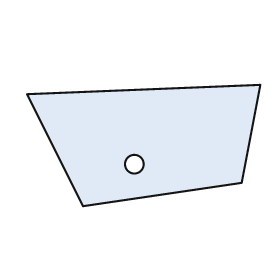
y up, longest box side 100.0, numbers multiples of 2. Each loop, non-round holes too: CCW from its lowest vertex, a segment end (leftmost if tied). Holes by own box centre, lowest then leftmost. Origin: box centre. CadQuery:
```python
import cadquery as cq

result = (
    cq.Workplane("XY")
    .moveTo(-26.0, -26.0)
    .lineTo(42.0, -16.0)
    .lineTo(50.0, 26.0)
    .lineTo(-50.0, 22.0)
    .close()
    .moveTo(-4.0, -8.0)
    .circle(4.0)
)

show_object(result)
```